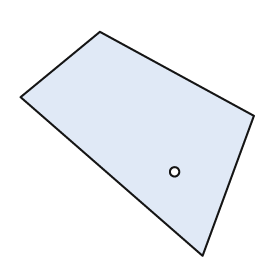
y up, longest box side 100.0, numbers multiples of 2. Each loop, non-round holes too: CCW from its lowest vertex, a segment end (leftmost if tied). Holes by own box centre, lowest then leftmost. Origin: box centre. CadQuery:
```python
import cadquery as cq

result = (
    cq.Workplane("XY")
    .moveTo(28.0, -48.0)
    .lineTo(50.0, 12.0)
    .lineTo(-16.0, 48.0)
    .lineTo(-50.0, 20.0)
    .close()
    .moveTo(16.0, -12.0)
    .circle(2.0)
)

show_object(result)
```